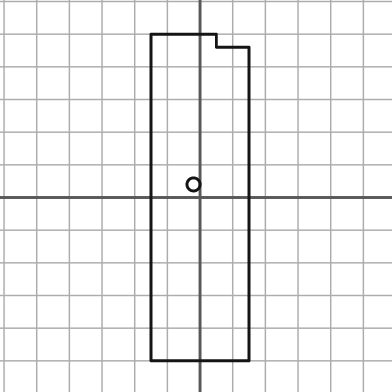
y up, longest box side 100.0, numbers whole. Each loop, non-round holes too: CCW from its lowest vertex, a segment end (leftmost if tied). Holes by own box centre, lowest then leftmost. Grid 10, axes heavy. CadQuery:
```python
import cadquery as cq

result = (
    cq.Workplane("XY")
    .moveTo(-15.0, -50.0)
    .lineTo(15.0, -50.0)
    .lineTo(15.0, 46.0)
    .lineTo(5.0, 46.0)
    .lineTo(5.0, 50.0)
    .lineTo(-15.0, 50.0)
    .close()
    .moveTo(-2.0, 4.0)
    .circle(2.0)
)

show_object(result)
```